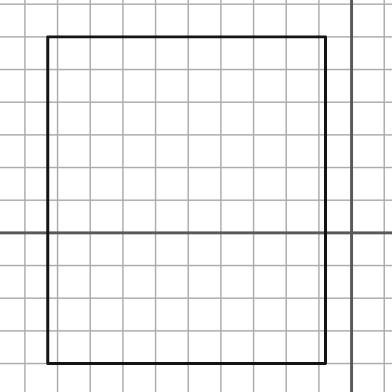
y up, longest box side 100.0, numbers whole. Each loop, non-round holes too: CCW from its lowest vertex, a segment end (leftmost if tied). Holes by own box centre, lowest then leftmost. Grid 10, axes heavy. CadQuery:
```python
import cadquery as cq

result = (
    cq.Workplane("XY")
    .moveTo(-93.0, -40.0)
    .lineTo(-8.0, -40.0)
    .lineTo(-8.0, 60.0)
    .lineTo(-93.0, 60.0)
    .close()
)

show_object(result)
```